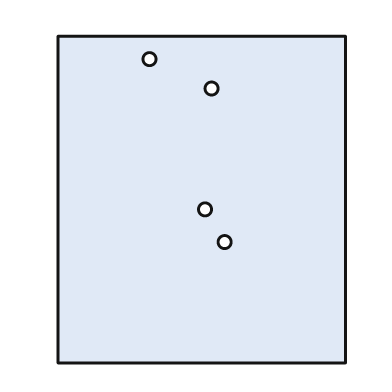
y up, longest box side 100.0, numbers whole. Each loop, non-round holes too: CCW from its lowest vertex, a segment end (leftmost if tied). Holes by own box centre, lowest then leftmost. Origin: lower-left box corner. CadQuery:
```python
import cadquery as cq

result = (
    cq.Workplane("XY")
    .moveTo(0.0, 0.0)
    .lineTo(88.0, 0.0)
    .lineTo(88.0, 100.0)
    .lineTo(0.0, 100.0)
    .close()
    .moveTo(51.0, 37.0)
    .circle(2.0)
    .moveTo(45.0, 47.0)
    .circle(2.0)
    .moveTo(47.0, 84.0)
    .circle(2.0)
    .moveTo(28.0, 93.0)
    .circle(2.0)
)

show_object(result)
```